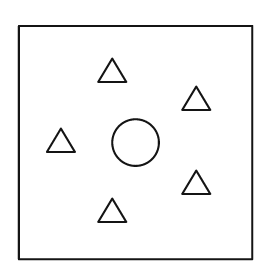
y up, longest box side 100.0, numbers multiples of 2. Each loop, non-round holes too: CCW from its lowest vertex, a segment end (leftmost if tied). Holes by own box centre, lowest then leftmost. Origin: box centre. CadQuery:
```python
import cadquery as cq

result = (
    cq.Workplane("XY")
    .moveTo(-50.0, -50.0)
    .lineTo(50.0, -50.0)
    .lineTo(50.0, 50.0)
    .lineTo(-50.0, 50.0)
    .close()
    .moveTo(-16.0, -34.0)
    .lineTo(-4.0, -34.0)
    .lineTo(-10.0, -24.0)
    .close()
    .moveTo(20.0, -22.0)
    .lineTo(32.0, -22.0)
    .lineTo(26.0, -12.0)
    .close()
    .moveTo(0.0, 0.0)
    .circle(10.0)
    .moveTo(-38.0, -4.0)
    .lineTo(-26.0, -4.0)
    .lineTo(-32.0, 6.0)
    .close()
    .moveTo(20.0, 14.0)
    .lineTo(32.0, 14.0)
    .lineTo(26.0, 24.0)
    .close()
    .moveTo(-16.0, 26.0)
    .lineTo(-4.0, 26.0)
    .lineTo(-10.0, 36.0)
    .close()
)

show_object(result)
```